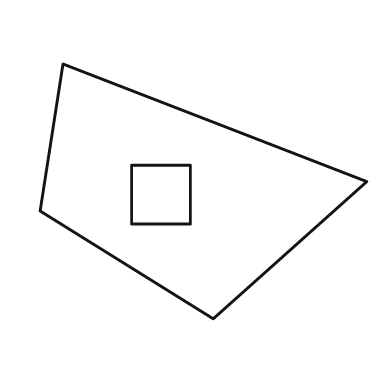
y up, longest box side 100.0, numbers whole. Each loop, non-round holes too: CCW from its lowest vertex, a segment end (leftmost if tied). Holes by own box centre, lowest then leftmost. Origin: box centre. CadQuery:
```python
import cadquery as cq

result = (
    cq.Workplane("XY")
    .moveTo(3.0, -39.0)
    .lineTo(50.0, 3.0)
    .lineTo(-43.0, 39.0)
    .lineTo(-50.0, -6.0)
    .close()
    .moveTo(-22.0, -10.0)
    .lineTo(-4.0, -10.0)
    .lineTo(-4.0, 8.0)
    .lineTo(-22.0, 8.0)
    .close()
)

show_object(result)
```